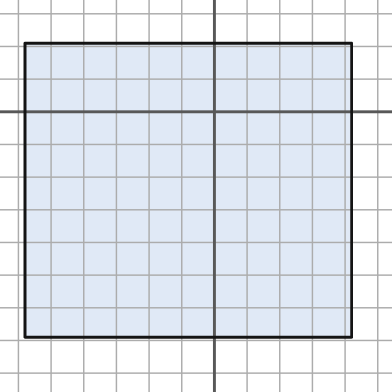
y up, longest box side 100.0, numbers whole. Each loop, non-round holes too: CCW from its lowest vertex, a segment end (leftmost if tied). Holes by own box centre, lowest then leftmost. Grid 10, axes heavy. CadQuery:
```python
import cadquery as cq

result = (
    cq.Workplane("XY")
    .moveTo(-58.0, -69.0)
    .lineTo(42.0, -69.0)
    .lineTo(42.0, 21.0)
    .lineTo(-58.0, 21.0)
    .close()
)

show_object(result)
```